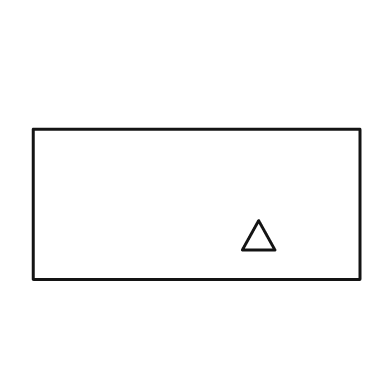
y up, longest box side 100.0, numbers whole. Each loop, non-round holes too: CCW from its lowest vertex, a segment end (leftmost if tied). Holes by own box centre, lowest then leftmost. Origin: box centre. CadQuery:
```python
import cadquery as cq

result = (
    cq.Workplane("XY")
    .moveTo(-50.0, -23.0)
    .lineTo(50.0, -23.0)
    .lineTo(50.0, 23.0)
    .lineTo(-50.0, 23.0)
    .close()
    .moveTo(14.0, -14.0)
    .lineTo(24.0, -14.0)
    .lineTo(19.0, -5.0)
    .close()
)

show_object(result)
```